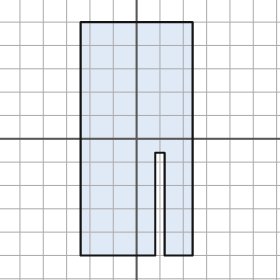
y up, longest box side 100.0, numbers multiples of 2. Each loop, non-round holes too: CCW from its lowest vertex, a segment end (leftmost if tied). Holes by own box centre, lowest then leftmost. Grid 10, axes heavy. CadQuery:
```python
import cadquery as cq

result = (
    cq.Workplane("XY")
    .moveTo(-24.0, -50.0)
    .lineTo(8.0, -50.0)
    .lineTo(8.0, -6.0)
    .lineTo(12.0, -6.0)
    .lineTo(12.0, -50.0)
    .lineTo(24.0, -50.0)
    .lineTo(24.0, 50.0)
    .lineTo(-24.0, 50.0)
    .close()
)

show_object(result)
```